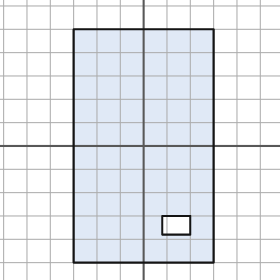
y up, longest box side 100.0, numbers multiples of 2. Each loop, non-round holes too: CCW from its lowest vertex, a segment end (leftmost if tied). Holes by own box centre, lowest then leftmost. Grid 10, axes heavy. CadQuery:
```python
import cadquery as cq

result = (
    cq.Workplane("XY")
    .moveTo(-30.0, -50.0)
    .lineTo(30.0, -50.0)
    .lineTo(30.0, 50.0)
    .lineTo(-30.0, 50.0)
    .close()
    .moveTo(8.0, -38.0)
    .lineTo(20.0, -38.0)
    .lineTo(20.0, -30.0)
    .lineTo(8.0, -30.0)
    .close()
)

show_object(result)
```